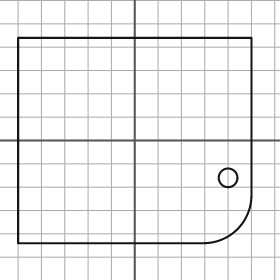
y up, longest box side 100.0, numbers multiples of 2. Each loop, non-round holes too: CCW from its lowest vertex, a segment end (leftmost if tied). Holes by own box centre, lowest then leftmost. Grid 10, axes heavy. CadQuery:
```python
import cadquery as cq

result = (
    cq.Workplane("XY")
    .moveTo(-50.0, -44.0)
    .lineTo(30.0, -44.0)
    .threePointArc((44.0, -38.0), (50.0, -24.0))
    .lineTo(50.0, 44.0)
    .lineTo(-50.0, 44.0)
    .close()
    .moveTo(40.0, -16.0)
    .circle(4.0)
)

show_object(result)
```